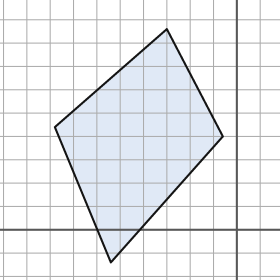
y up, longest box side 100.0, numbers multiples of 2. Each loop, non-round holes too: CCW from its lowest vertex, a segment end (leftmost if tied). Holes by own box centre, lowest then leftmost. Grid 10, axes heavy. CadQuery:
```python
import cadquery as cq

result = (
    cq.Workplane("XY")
    .moveTo(-54.0, -14.0)
    .lineTo(-6.0, 40.0)
    .lineTo(-30.0, 86.0)
    .lineTo(-78.0, 44.0)
    .close()
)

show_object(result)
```